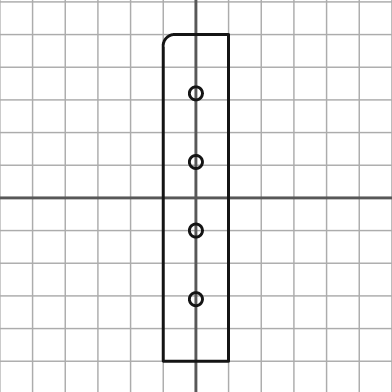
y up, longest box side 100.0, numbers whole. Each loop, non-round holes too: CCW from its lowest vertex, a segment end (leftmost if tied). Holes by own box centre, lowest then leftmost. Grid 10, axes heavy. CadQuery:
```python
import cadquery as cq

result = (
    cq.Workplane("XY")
    .moveTo(-10.0, -50.0)
    .lineTo(10.0, -50.0)
    .lineTo(10.0, 50.0)
    .lineTo(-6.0, 50.0)
    .threePointArc((-9.0, 49.0), (-10.0, 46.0))
    .close()
    .moveTo(0.0, -31.0)
    .circle(2.0)
    .moveTo(0.0, -10.0)
    .circle(2.0)
    .moveTo(0.0, 11.0)
    .circle(2.0)
    .moveTo(0.0, 32.0)
    .circle(2.0)
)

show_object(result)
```